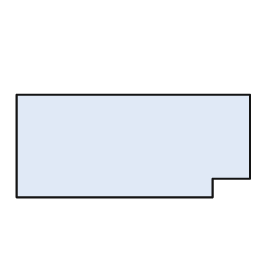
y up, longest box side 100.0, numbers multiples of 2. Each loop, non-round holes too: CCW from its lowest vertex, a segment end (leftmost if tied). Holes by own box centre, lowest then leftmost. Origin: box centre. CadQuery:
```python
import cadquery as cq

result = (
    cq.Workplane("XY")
    .moveTo(-50.0, -22.0)
    .lineTo(34.0, -22.0)
    .lineTo(34.0, -14.0)
    .lineTo(50.0, -14.0)
    .lineTo(50.0, 22.0)
    .lineTo(-50.0, 22.0)
    .close()
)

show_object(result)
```